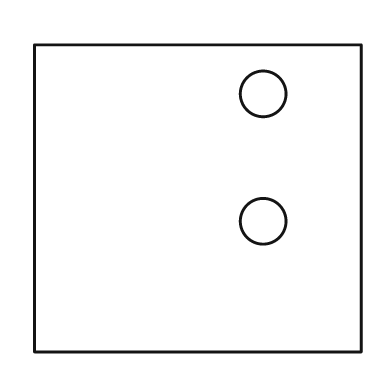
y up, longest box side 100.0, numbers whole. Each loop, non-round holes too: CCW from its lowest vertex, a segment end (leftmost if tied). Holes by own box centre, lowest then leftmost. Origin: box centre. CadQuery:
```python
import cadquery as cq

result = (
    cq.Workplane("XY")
    .moveTo(-50.0, -47.0)
    .lineTo(50.0, -47.0)
    .lineTo(50.0, 47.0)
    .lineTo(-50.0, 47.0)
    .close()
    .moveTo(20.0, -7.0)
    .circle(7.0)
    .moveTo(20.0, 32.0)
    .circle(7.0)
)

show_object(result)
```